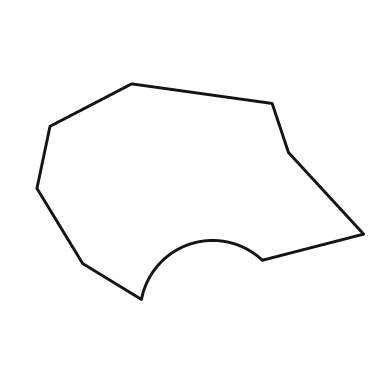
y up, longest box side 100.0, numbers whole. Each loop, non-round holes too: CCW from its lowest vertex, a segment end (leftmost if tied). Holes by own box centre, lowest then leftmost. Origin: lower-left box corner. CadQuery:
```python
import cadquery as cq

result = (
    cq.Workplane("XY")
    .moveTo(32.0, 0.0)
    .threePointArc((47.0, 17.0), (69.0, 12.0))
    .lineTo(100.0, 20.0)
    .lineTo(77.0, 45.0)
    .lineTo(72.0, 60.0)
    .lineTo(29.0, 66.0)
    .lineTo(4.0, 53.0)
    .lineTo(0.0, 34.0)
    .lineTo(14.0, 11.0)
    .close()
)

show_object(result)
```